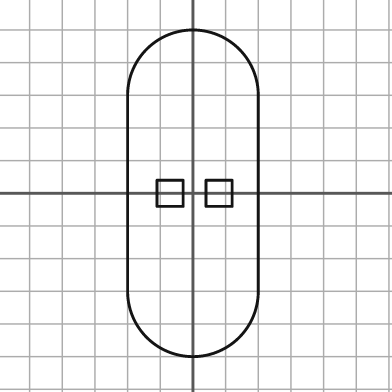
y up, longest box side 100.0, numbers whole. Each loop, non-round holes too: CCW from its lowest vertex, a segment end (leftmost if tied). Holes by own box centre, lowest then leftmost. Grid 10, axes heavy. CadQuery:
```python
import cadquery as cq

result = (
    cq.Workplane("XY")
    .moveTo(-20.0, -30.0)
    .threePointArc((0.0, -50.0), (20.0, -30.0))
    .lineTo(20.0, 30.0)
    .threePointArc((0.0, 50.0), (-20.0, 30.0))
    .close()
    .moveTo(-11.0, -4.0)
    .lineTo(-3.0, -4.0)
    .lineTo(-3.0, 4.0)
    .lineTo(-11.0, 4.0)
    .close()
    .moveTo(4.0, -4.0)
    .lineTo(12.0, -4.0)
    .lineTo(12.0, 4.0)
    .lineTo(4.0, 4.0)
    .close()
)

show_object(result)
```